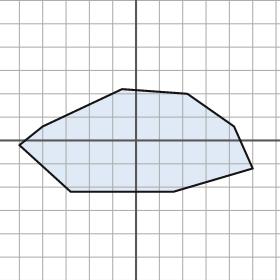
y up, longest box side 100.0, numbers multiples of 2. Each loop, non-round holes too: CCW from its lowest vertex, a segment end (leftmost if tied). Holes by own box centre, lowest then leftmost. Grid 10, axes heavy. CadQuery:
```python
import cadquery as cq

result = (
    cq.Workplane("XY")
    .moveTo(-28.0, -22.0)
    .lineTo(16.0, -22.0)
    .lineTo(50.0, -12.0)
    .lineTo(42.0, 6.0)
    .lineTo(22.0, 20.0)
    .lineTo(-6.0, 22.0)
    .lineTo(-40.0, 6.0)
    .lineTo(-50.0, -2.0)
    .close()
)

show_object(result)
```